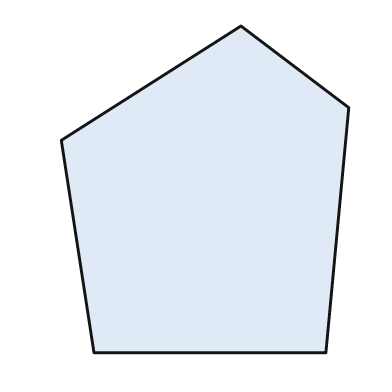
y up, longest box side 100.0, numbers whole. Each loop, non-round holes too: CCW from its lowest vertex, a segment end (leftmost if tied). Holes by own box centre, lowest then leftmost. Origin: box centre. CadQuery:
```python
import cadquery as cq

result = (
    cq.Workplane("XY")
    .moveTo(-34.0, -50.0)
    .lineTo(37.0, -50.0)
    .lineTo(44.0, 25.0)
    .lineTo(11.0, 50.0)
    .lineTo(-44.0, 15.0)
    .close()
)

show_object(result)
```